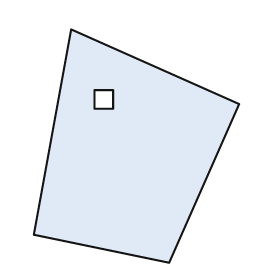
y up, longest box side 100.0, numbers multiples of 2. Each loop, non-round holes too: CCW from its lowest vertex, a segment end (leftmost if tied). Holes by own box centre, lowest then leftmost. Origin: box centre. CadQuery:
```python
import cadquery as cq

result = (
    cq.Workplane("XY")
    .moveTo(14.0, -50.0)
    .lineTo(44.0, 18.0)
    .lineTo(-28.0, 50.0)
    .lineTo(-44.0, -38.0)
    .close()
    .moveTo(-18.0, 16.0)
    .lineTo(-10.0, 16.0)
    .lineTo(-10.0, 24.0)
    .lineTo(-18.0, 24.0)
    .close()
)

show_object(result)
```